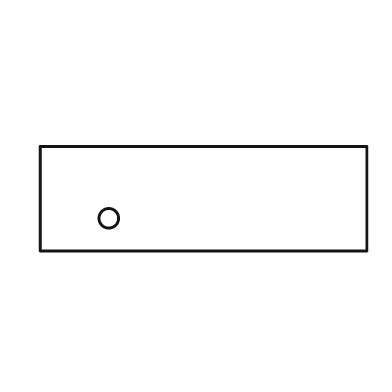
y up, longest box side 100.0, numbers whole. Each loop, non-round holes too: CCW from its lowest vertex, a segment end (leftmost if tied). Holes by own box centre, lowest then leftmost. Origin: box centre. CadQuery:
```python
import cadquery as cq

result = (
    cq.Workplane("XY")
    .moveTo(-50.0, -16.0)
    .lineTo(50.0, -16.0)
    .lineTo(50.0, 16.0)
    .lineTo(-50.0, 16.0)
    .close()
    .moveTo(-29.0, -6.0)
    .circle(3.0)
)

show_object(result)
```